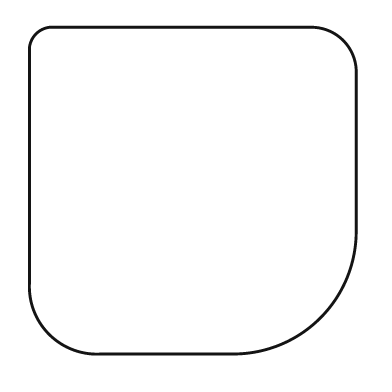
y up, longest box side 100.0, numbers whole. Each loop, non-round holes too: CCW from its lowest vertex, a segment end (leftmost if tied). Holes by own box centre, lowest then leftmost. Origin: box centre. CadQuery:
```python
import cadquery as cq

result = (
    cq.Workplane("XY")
    .moveTo(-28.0, -50.0)
    .lineTo(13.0, -50.0)
    .threePointArc((39.0, -39.0), (50.0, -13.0))
    .lineTo(50.0, 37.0)
    .threePointArc((46.0, 46.0), (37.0, 50.0))
    .lineTo(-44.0, 50.0)
    .threePointArc((-48.0, 48.0), (-50.0, 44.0))
    .lineTo(-50.0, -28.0)
    .threePointArc((-44.0, -44.0), (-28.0, -50.0))
    .close()
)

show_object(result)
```